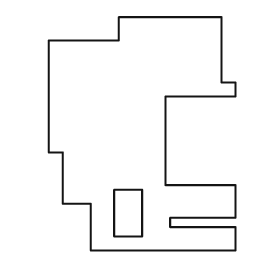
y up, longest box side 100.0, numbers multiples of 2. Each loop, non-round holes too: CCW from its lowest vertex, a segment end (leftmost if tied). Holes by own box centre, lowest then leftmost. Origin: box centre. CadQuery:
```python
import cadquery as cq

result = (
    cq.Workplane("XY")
    .moveTo(-22.0, -50.0)
    .lineTo(40.0, -50.0)
    .lineTo(40.0, -40.0)
    .lineTo(12.0, -40.0)
    .lineTo(12.0, -36.0)
    .lineTo(40.0, -36.0)
    .lineTo(40.0, -22.0)
    .lineTo(10.0, -22.0)
    .lineTo(10.0, 16.0)
    .lineTo(40.0, 16.0)
    .lineTo(40.0, 22.0)
    .lineTo(34.0, 22.0)
    .lineTo(34.0, 50.0)
    .lineTo(-10.0, 50.0)
    .lineTo(-10.0, 40.0)
    .lineTo(-40.0, 40.0)
    .lineTo(-40.0, -8.0)
    .lineTo(-34.0, -8.0)
    .lineTo(-34.0, -30.0)
    .lineTo(-22.0, -30.0)
    .close()
    .moveTo(-12.0, -44.0)
    .lineTo(0.0, -44.0)
    .lineTo(0.0, -24.0)
    .lineTo(-12.0, -24.0)
    .close()
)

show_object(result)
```